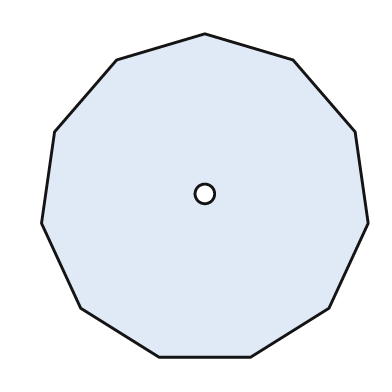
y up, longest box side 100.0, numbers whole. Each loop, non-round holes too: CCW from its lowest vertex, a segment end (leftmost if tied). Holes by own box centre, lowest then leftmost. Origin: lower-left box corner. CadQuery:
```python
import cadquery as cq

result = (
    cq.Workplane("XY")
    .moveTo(36.0, 0.0)
    .lineTo(64.0, 0.0)
    .lineTo(88.0, 15.0)
    .lineTo(100.0, 41.0)
    .lineTo(96.0, 69.0)
    .lineTo(77.0, 91.0)
    .lineTo(50.0, 99.0)
    .lineTo(23.0, 91.0)
    .lineTo(4.0, 69.0)
    .lineTo(0.0, 41.0)
    .lineTo(12.0, 15.0)
    .close()
    .moveTo(50.0, 50.0)
    .circle(3.0)
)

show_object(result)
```